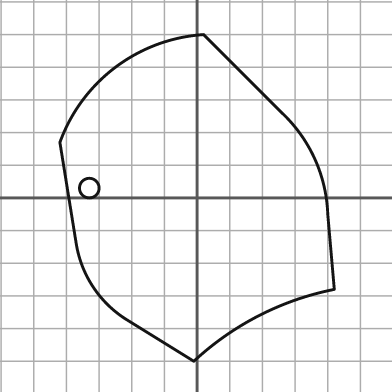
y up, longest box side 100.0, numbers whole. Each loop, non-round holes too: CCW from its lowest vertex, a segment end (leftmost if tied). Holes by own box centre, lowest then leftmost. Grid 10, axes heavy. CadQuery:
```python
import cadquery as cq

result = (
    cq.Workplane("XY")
    .moveTo(-1.0, -50.0)
    .threePointArc((19.0, -36.0), (42.0, -28.0))
    .lineTo(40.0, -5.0)
    .threePointArc((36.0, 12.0), (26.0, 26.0))
    .lineTo(2.0, 50.0)
    .threePointArc((-25.0, 40.0), (-42.0, 17.0))
    .lineTo(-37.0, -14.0)
    .threePointArc((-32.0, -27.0), (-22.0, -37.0))
    .close()
    .moveTo(-33.0, 3.0)
    .circle(3.0)
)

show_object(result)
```